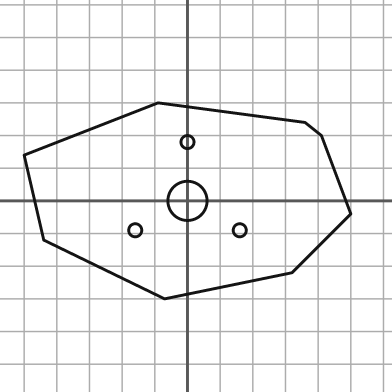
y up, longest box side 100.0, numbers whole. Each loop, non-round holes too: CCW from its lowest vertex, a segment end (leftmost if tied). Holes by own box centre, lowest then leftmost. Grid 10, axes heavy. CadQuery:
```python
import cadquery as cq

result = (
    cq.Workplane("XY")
    .moveTo(-7.0, -30.0)
    .lineTo(32.0, -22.0)
    .lineTo(50.0, -4.0)
    .lineTo(41.0, 20.0)
    .lineTo(36.0, 24.0)
    .lineTo(-9.0, 30.0)
    .lineTo(-50.0, 14.0)
    .lineTo(-44.0, -12.0)
    .close()
    .moveTo(-16.0, -9.0)
    .circle(2.0)
    .moveTo(16.0, -9.0)
    .circle(2.0)
    .moveTo(0.0, 0.0)
    .circle(6.0)
    .moveTo(0.0, 18.0)
    .circle(2.0)
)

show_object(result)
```